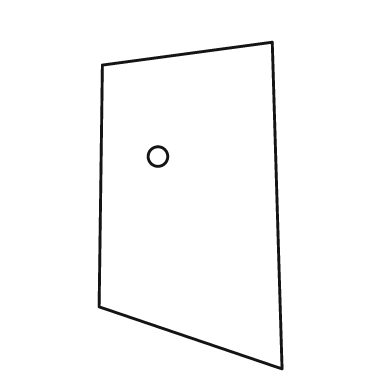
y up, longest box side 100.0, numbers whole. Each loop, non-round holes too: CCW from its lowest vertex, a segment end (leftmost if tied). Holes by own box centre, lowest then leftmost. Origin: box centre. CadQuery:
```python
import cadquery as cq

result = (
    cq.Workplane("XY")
    .moveTo(28.0, -50.0)
    .lineTo(25.0, 50.0)
    .lineTo(-27.0, 43.0)
    .lineTo(-28.0, -31.0)
    .close()
    .moveTo(-10.0, 15.0)
    .circle(3.0)
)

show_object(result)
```